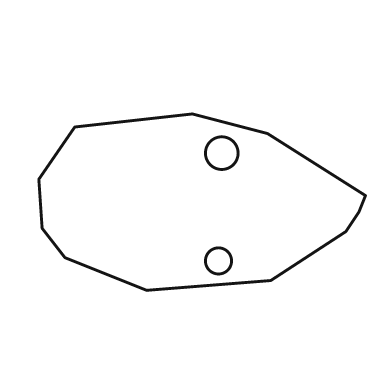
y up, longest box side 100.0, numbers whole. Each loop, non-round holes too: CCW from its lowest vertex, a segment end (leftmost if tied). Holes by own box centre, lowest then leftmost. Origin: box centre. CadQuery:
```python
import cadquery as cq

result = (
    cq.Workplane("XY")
    .moveTo(-17.0, -27.0)
    .lineTo(21.0, -24.0)
    .lineTo(44.0, -9.0)
    .lineTo(48.0, -3.0)
    .lineTo(50.0, 2.0)
    .lineTo(20.0, 21.0)
    .lineTo(-3.0, 27.0)
    .lineTo(-39.0, 23.0)
    .lineTo(-50.0, 7.0)
    .lineTo(-49.0, -8.0)
    .lineTo(-42.0, -17.0)
    .close()
    .moveTo(5.0, -18.0)
    .circle(4.0)
    .moveTo(6.0, 15.0)
    .circle(5.0)
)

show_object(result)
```